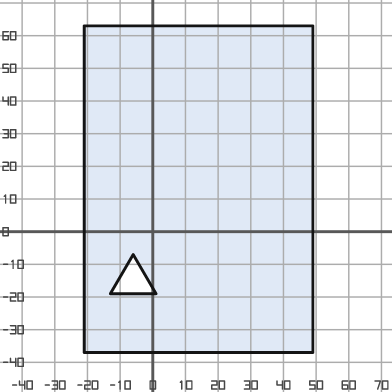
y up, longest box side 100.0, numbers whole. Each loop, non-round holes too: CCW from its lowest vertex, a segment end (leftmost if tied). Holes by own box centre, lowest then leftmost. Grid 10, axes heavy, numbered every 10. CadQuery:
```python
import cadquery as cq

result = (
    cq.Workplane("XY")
    .moveTo(-21.0, -37.0)
    .lineTo(49.0, -37.0)
    .lineTo(49.0, 63.0)
    .lineTo(-21.0, 63.0)
    .close()
    .moveTo(-13.0, -19.0)
    .lineTo(1.0, -19.0)
    .lineTo(-6.0, -7.0)
    .close()
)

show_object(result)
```